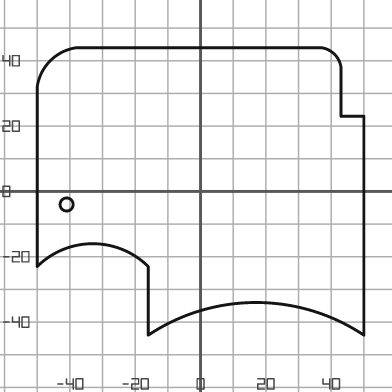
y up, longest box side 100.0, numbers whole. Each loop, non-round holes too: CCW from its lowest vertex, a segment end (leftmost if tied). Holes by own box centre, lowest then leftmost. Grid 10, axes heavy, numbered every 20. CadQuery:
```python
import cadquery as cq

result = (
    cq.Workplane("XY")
    .moveTo(-16.0, -44.0)
    .threePointArc((17.0, -34.0), (50.0, -44.0))
    .lineTo(50.0, 23.0)
    .lineTo(43.0, 23.0)
    .lineTo(43.0, 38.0)
    .threePointArc((41.0, 42.0), (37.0, 44.0))
    .lineTo(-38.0, 44.0)
    .threePointArc((-46.0, 40.0), (-50.0, 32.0))
    .lineTo(-50.0, -23.0)
    .threePointArc((-33.0, -16.0), (-16.0, -23.0))
    .close()
    .moveTo(-41.0, -4.0)
    .circle(2.0)
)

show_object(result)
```